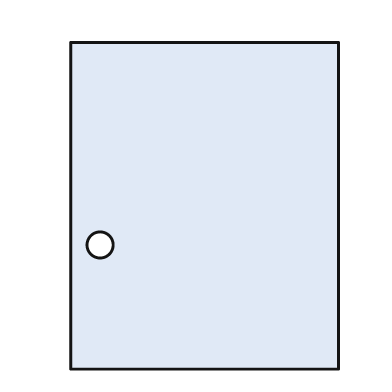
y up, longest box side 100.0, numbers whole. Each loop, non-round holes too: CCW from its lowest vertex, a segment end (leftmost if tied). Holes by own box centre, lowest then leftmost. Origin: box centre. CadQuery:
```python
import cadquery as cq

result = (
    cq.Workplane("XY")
    .moveTo(-41.0, -50.0)
    .lineTo(41.0, -50.0)
    .lineTo(41.0, 50.0)
    .lineTo(-41.0, 50.0)
    .close()
    .moveTo(-32.0, -12.0)
    .circle(4.0)
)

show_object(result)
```